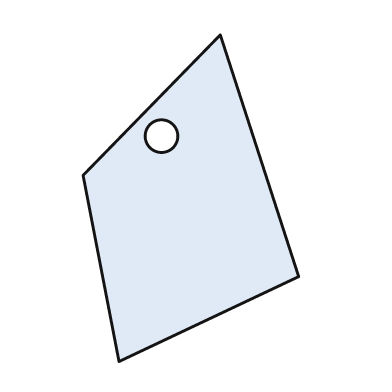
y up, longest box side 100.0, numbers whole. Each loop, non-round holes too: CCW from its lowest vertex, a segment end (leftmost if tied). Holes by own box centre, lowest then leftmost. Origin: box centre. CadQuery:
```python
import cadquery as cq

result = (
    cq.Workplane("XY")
    .moveTo(-22.0, -50.0)
    .lineTo(33.0, -24.0)
    .lineTo(9.0, 50.0)
    .lineTo(-33.0, 7.0)
    .close()
    .moveTo(-9.0, 19.0)
    .circle(5.0)
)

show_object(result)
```